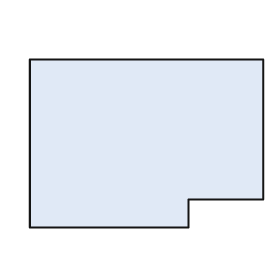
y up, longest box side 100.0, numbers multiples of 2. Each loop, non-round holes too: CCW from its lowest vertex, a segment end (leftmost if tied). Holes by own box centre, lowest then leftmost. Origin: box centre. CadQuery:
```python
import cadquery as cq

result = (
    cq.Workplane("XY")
    .moveTo(-50.0, -36.0)
    .lineTo(18.0, -36.0)
    .lineTo(18.0, -24.0)
    .lineTo(50.0, -24.0)
    .lineTo(50.0, 36.0)
    .lineTo(-50.0, 36.0)
    .close()
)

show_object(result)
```